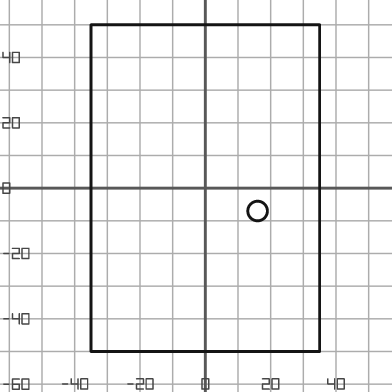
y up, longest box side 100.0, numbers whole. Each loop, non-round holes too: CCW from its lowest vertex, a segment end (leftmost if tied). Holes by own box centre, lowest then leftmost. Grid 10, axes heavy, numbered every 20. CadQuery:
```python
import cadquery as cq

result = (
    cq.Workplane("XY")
    .moveTo(-35.0, -50.0)
    .lineTo(35.0, -50.0)
    .lineTo(35.0, 50.0)
    .lineTo(-35.0, 50.0)
    .close()
    .moveTo(16.0, -7.0)
    .circle(3.0)
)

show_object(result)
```